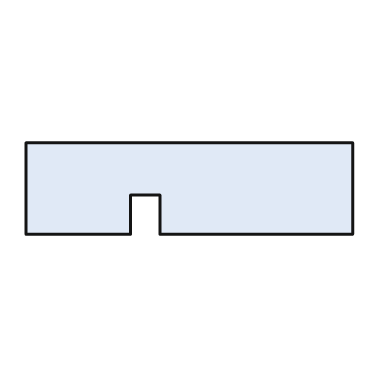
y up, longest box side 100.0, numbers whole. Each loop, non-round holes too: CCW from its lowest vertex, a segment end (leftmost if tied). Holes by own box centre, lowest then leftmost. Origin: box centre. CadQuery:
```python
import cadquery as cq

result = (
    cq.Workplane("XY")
    .moveTo(-50.0, -14.0)
    .lineTo(-18.0, -14.0)
    .lineTo(-18.0, -2.0)
    .lineTo(-9.0, -2.0)
    .lineTo(-9.0, -14.0)
    .lineTo(50.0, -14.0)
    .lineTo(50.0, 14.0)
    .lineTo(-50.0, 14.0)
    .close()
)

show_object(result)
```